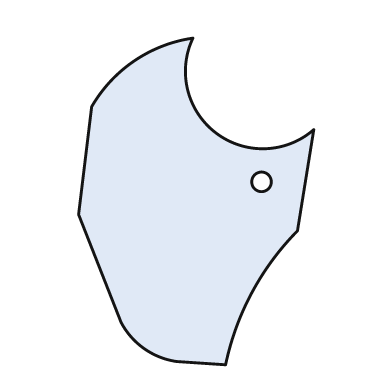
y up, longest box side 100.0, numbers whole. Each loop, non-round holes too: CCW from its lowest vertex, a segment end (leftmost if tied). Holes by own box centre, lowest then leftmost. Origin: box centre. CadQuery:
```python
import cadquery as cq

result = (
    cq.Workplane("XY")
    .moveTo(9.0, -50.0)
    .threePointArc((17.0, -28.0), (31.0, -9.0))
    .lineTo(36.0, 22.0)
    .threePointArc((6.0, 21.0), (-1.0, 50.0))
    .threePointArc((-19.0, 43.0), (-32.0, 29.0))
    .lineTo(-36.0, -4.0)
    .lineTo(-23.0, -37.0)
    .threePointArc((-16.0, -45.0), (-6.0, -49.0))
    .close()
    .moveTo(20.0, 6.0)
    .circle(3.0)
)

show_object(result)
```